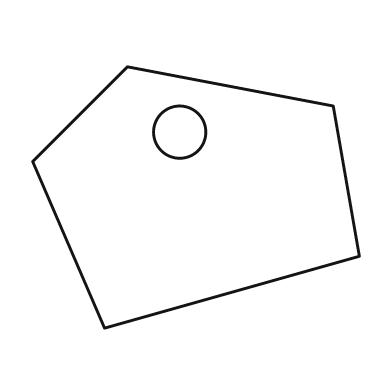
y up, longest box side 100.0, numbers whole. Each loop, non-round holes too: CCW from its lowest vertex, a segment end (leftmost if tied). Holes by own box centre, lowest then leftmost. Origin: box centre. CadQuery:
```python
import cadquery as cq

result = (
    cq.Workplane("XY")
    .moveTo(-28.0, -40.0)
    .lineTo(50.0, -18.0)
    .lineTo(42.0, 28.0)
    .lineTo(-21.0, 40.0)
    .lineTo(-50.0, 11.0)
    .close()
    .moveTo(-5.0, 20.0)
    .circle(8.0)
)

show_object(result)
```